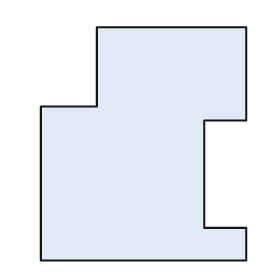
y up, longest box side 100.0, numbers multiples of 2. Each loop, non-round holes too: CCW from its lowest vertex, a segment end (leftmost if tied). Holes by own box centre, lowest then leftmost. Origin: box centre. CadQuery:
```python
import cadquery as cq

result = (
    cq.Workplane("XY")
    .moveTo(-44.0, -50.0)
    .lineTo(44.0, -50.0)
    .lineTo(44.0, -36.0)
    .lineTo(26.0, -36.0)
    .lineTo(26.0, 10.0)
    .lineTo(44.0, 10.0)
    .lineTo(44.0, 50.0)
    .lineTo(-20.0, 50.0)
    .lineTo(-20.0, 16.0)
    .lineTo(-44.0, 16.0)
    .close()
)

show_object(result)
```